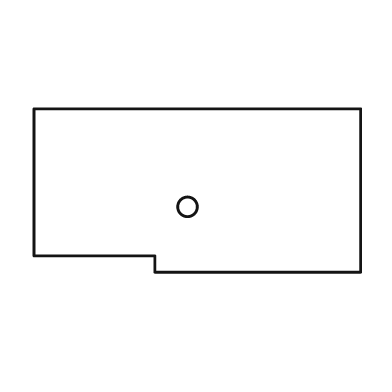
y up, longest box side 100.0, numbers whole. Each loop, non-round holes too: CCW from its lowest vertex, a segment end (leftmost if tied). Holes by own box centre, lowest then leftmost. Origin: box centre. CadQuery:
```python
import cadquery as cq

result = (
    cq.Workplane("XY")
    .moveTo(-13.0, -25.0)
    .lineTo(50.0, -25.0)
    .lineTo(50.0, 25.0)
    .lineTo(-50.0, 25.0)
    .lineTo(-50.0, -20.0)
    .lineTo(-13.0, -20.0)
    .close()
    .moveTo(-3.0, -5.0)
    .circle(3.0)
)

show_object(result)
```